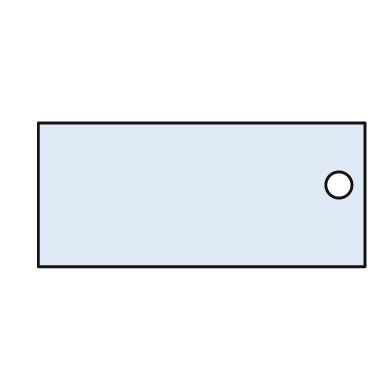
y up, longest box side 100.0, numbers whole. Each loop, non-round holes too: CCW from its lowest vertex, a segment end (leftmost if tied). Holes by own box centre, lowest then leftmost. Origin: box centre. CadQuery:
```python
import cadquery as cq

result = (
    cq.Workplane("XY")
    .moveTo(-50.0, -22.0)
    .lineTo(50.0, -22.0)
    .lineTo(50.0, 22.0)
    .lineTo(-50.0, 22.0)
    .close()
    .moveTo(42.0, 3.0)
    .circle(4.0)
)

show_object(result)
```